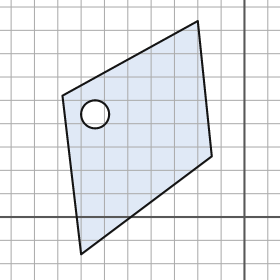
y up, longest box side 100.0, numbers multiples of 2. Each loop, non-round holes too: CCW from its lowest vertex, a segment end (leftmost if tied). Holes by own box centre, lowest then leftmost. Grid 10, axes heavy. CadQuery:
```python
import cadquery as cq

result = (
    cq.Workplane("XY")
    .moveTo(-70.0, -16.0)
    .lineTo(-14.0, 26.0)
    .lineTo(-20.0, 84.0)
    .lineTo(-78.0, 52.0)
    .close()
    .moveTo(-64.0, 44.0)
    .circle(6.0)
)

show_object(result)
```